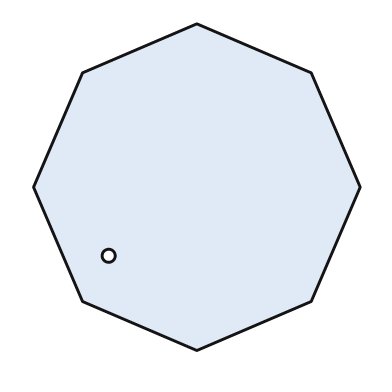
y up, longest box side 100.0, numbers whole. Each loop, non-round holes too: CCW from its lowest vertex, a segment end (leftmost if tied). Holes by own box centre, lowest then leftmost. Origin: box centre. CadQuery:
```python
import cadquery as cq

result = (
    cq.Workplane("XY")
    .moveTo(0.0, -50.0)
    .lineTo(35.0, -35.0)
    .lineTo(50.0, 0.0)
    .lineTo(35.0, 35.0)
    .lineTo(0.0, 50.0)
    .lineTo(-35.0, 35.0)
    .lineTo(-50.0, 0.0)
    .lineTo(-35.0, -35.0)
    .close()
    .moveTo(-27.0, -21.0)
    .circle(2.0)
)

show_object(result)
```